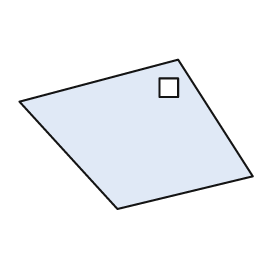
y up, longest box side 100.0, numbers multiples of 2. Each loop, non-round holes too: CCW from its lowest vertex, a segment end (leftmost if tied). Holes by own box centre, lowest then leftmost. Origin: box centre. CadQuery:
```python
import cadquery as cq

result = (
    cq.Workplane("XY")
    .moveTo(-8.0, -32.0)
    .lineTo(50.0, -18.0)
    .lineTo(18.0, 32.0)
    .lineTo(-50.0, 14.0)
    .close()
    .moveTo(10.0, 16.0)
    .lineTo(18.0, 16.0)
    .lineTo(18.0, 24.0)
    .lineTo(10.0, 24.0)
    .close()
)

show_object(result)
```